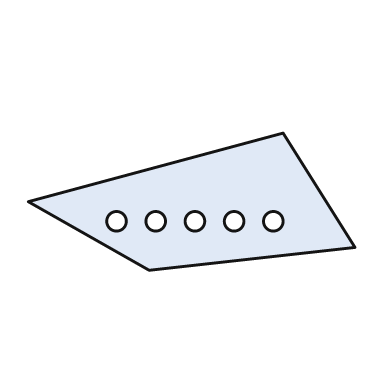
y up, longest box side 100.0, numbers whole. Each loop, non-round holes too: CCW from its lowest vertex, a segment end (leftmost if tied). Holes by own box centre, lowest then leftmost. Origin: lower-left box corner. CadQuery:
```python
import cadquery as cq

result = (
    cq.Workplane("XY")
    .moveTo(37.0, 0.0)
    .lineTo(100.0, 7.0)
    .lineTo(78.0, 42.0)
    .lineTo(0.0, 21.0)
    .close()
    .moveTo(27.0, 15.0)
    .circle(3.0)
    .moveTo(39.0, 15.0)
    .circle(3.0)
    .moveTo(51.0, 15.0)
    .circle(3.0)
    .moveTo(63.0, 15.0)
    .circle(3.0)
    .moveTo(75.0, 15.0)
    .circle(3.0)
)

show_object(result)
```